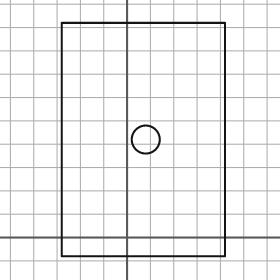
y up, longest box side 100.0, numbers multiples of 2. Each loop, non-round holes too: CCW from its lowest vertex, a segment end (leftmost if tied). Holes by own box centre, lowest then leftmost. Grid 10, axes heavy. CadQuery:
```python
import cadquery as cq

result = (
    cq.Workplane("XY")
    .moveTo(-28.0, -8.0)
    .lineTo(42.0, -8.0)
    .lineTo(42.0, 92.0)
    .lineTo(-28.0, 92.0)
    .close()
    .moveTo(8.0, 42.0)
    .circle(6.0)
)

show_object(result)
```